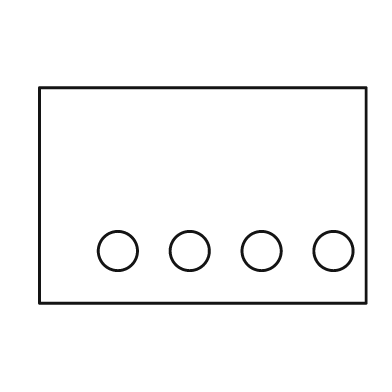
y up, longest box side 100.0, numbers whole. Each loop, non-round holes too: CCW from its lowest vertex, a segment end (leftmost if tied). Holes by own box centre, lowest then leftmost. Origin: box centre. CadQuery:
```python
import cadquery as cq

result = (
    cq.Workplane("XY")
    .moveTo(-50.0, -33.0)
    .lineTo(50.0, -33.0)
    .lineTo(50.0, 33.0)
    .lineTo(-50.0, 33.0)
    .close()
    .moveTo(-26.0, -17.0)
    .circle(6.0)
    .moveTo(-4.0, -17.0)
    .circle(6.0)
    .moveTo(18.0, -17.0)
    .circle(6.0)
    .moveTo(40.0, -17.0)
    .circle(6.0)
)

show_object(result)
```